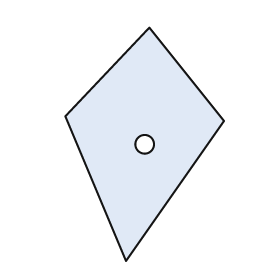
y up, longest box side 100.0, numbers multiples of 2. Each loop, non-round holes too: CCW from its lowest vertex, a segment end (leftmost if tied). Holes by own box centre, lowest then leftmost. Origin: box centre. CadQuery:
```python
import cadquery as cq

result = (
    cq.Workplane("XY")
    .moveTo(-8.0, -50.0)
    .lineTo(34.0, 10.0)
    .lineTo(2.0, 50.0)
    .lineTo(-34.0, 12.0)
    .close()
    .moveTo(0.0, 0.0)
    .circle(4.0)
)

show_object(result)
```